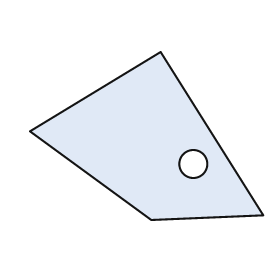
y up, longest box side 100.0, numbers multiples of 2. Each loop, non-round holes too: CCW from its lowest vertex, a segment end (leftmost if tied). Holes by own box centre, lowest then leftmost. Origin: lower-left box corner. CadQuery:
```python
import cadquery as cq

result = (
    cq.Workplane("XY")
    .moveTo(52.0, 0.0)
    .lineTo(100.0, 2.0)
    .lineTo(56.0, 72.0)
    .lineTo(0.0, 38.0)
    .close()
    .moveTo(70.0, 24.0)
    .circle(6.0)
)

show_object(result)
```